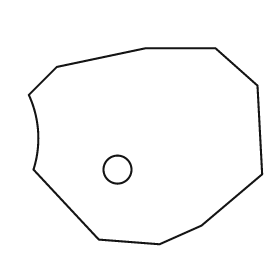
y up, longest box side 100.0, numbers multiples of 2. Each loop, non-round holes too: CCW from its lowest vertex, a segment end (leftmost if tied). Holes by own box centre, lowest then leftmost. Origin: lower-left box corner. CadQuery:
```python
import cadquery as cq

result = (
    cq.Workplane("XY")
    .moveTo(56.0, 0.0)
    .lineTo(74.0, 8.0)
    .lineTo(100.0, 30.0)
    .lineTo(98.0, 68.0)
    .lineTo(80.0, 84.0)
    .lineTo(50.0, 84.0)
    .lineTo(12.0, 76.0)
    .lineTo(0.0, 64.0)
    .threePointArc((4.0, 48.0), (2.0, 32.0))
    .lineTo(30.0, 2.0)
    .close()
    .moveTo(38.0, 32.0)
    .circle(6.0)
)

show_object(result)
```